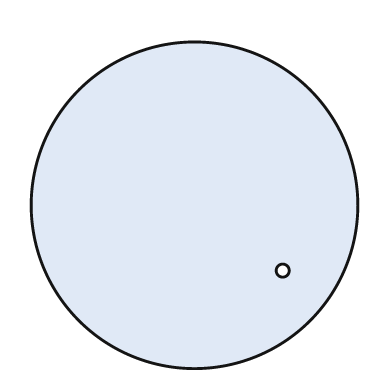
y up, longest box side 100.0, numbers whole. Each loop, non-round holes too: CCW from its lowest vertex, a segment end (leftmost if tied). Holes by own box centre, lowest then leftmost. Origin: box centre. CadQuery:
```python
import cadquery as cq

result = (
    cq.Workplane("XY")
    .moveTo(0.0, 0.0)
    .circle(50.0)
    .moveTo(27.0, -20.0)
    .circle(2.0)
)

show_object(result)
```